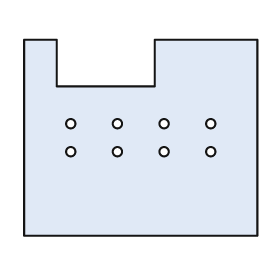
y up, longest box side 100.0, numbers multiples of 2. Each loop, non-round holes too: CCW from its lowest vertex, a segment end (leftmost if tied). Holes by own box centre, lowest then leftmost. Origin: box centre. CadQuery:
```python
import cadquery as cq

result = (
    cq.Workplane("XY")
    .moveTo(-50.0, -42.0)
    .lineTo(50.0, -42.0)
    .lineTo(50.0, 42.0)
    .lineTo(6.0, 42.0)
    .lineTo(6.0, 22.0)
    .lineTo(-36.0, 22.0)
    .lineTo(-36.0, 42.0)
    .lineTo(-50.0, 42.0)
    .close()
    .moveTo(-30.0, -6.0)
    .circle(2.0)
    .moveTo(-10.0, -6.0)
    .circle(2.0)
    .moveTo(10.0, -6.0)
    .circle(2.0)
    .moveTo(30.0, -6.0)
    .circle(2.0)
    .moveTo(-30.0, 6.0)
    .circle(2.0)
    .moveTo(-10.0, 6.0)
    .circle(2.0)
    .moveTo(10.0, 6.0)
    .circle(2.0)
    .moveTo(30.0, 6.0)
    .circle(2.0)
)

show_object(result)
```